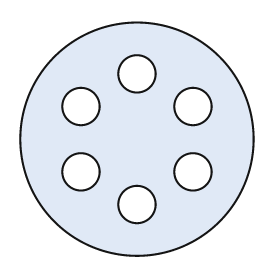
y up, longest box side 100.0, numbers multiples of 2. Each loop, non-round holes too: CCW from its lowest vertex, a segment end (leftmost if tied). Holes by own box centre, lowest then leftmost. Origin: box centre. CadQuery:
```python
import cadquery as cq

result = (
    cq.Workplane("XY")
    .moveTo(0.0, 0.0)
    .circle(50.0)
    .moveTo(0.0, -28.0)
    .circle(8.0)
    .moveTo(-24.0, -14.0)
    .circle(8.0)
    .moveTo(24.0, -14.0)
    .circle(8.0)
    .moveTo(-24.0, 14.0)
    .circle(8.0)
    .moveTo(24.0, 14.0)
    .circle(8.0)
    .moveTo(0.0, 28.0)
    .circle(8.0)
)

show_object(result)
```